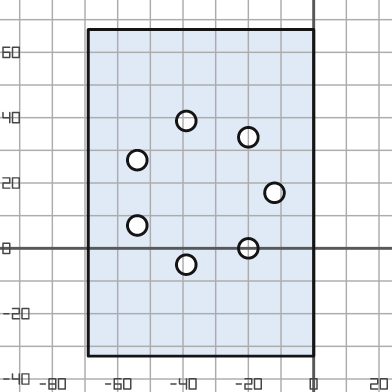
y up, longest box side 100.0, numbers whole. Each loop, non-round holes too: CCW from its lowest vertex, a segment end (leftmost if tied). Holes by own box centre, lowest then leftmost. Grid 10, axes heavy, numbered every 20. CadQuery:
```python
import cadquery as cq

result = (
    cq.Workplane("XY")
    .moveTo(-69.0, -33.0)
    .lineTo(0.0, -33.0)
    .lineTo(0.0, 67.0)
    .lineTo(-69.0, 67.0)
    .close()
    .moveTo(-39.0, -5.0)
    .circle(3.0)
    .moveTo(-20.0, 0.0)
    .circle(3.0)
    .moveTo(-54.0, 7.0)
    .circle(3.0)
    .moveTo(-12.0, 17.0)
    .circle(3.0)
    .moveTo(-54.0, 27.0)
    .circle(3.0)
    .moveTo(-20.0, 34.0)
    .circle(3.0)
    .moveTo(-39.0, 39.0)
    .circle(3.0)
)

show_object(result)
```